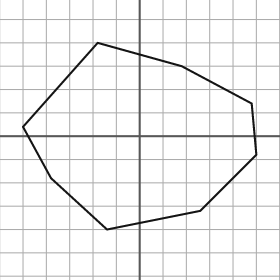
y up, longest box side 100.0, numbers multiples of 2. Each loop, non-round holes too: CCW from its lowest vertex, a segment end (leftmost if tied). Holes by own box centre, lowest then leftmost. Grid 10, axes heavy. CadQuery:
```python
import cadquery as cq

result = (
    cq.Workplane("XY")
    .moveTo(-14.0, -40.0)
    .lineTo(26.0, -32.0)
    .lineTo(50.0, -8.0)
    .lineTo(48.0, 14.0)
    .lineTo(18.0, 30.0)
    .lineTo(-18.0, 40.0)
    .lineTo(-50.0, 4.0)
    .lineTo(-38.0, -18.0)
    .close()
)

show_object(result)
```